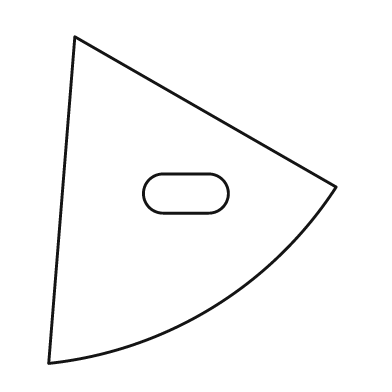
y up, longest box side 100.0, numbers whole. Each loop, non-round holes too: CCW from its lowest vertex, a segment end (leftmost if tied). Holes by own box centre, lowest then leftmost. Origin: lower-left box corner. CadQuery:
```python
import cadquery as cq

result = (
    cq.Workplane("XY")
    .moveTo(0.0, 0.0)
    .threePointArc((50.0, 17.0), (88.0, 54.0))
    .lineTo(8.0, 100.0)
    .close()
    .moveTo(35.0, 46.0)
    .lineTo(49.0, 46.0)
    .threePointArc((55.0, 52.0), (49.0, 58.0))
    .lineTo(35.0, 58.0)
    .threePointArc((29.0, 52.0), (35.0, 46.0))
    .close()
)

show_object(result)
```